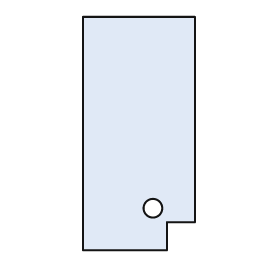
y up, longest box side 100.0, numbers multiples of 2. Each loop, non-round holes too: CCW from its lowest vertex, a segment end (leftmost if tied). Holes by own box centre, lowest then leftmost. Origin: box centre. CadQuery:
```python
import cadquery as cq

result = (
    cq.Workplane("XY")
    .moveTo(-24.0, -50.0)
    .lineTo(12.0, -50.0)
    .lineTo(12.0, -38.0)
    .lineTo(24.0, -38.0)
    .lineTo(24.0, 50.0)
    .lineTo(-24.0, 50.0)
    .close()
    .moveTo(6.0, -32.0)
    .circle(4.0)
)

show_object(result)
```